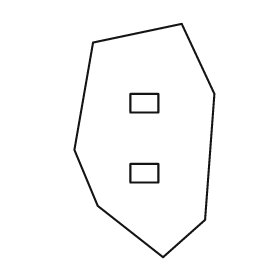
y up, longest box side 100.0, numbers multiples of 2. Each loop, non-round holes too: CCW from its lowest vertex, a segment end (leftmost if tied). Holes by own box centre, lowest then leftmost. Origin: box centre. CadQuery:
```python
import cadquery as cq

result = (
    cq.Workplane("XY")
    .moveTo(8.0, -50.0)
    .lineTo(26.0, -34.0)
    .lineTo(30.0, 20.0)
    .lineTo(16.0, 50.0)
    .lineTo(-22.0, 42.0)
    .lineTo(-30.0, -4.0)
    .lineTo(-20.0, -28.0)
    .close()
    .moveTo(-6.0, -18.0)
    .lineTo(6.0, -18.0)
    .lineTo(6.0, -10.0)
    .lineTo(-6.0, -10.0)
    .close()
    .moveTo(-6.0, 12.0)
    .lineTo(6.0, 12.0)
    .lineTo(6.0, 20.0)
    .lineTo(-6.0, 20.0)
    .close()
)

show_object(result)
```